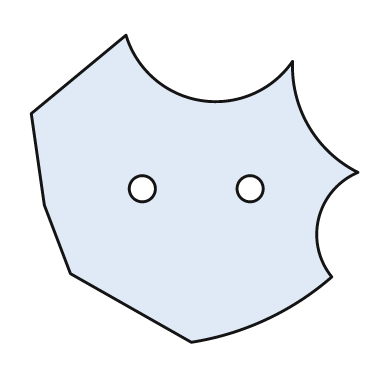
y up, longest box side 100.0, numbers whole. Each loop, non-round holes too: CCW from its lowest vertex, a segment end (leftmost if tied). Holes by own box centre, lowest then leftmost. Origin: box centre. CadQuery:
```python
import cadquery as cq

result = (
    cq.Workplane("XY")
    .moveTo(-1.0, -47.0)
    .threePointArc((22.0, -40.0), (42.0, -27.0))
    .threePointArc((38.0, -9.0), (50.0, 5.0))
    .threePointArc((35.0, 19.0), (30.0, 39.0))
    .threePointArc((2.0, 27.0), (-21.0, 47.0))
    .lineTo(-50.0, 23.0)
    .lineTo(-46.0, -5.0)
    .lineTo(-38.0, -26.0)
    .close()
    .moveTo(-16.0, 0.0)
    .circle(4.0)
    .moveTo(17.0, 0.0)
    .circle(4.0)
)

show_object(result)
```